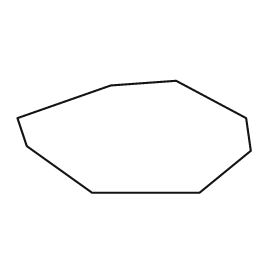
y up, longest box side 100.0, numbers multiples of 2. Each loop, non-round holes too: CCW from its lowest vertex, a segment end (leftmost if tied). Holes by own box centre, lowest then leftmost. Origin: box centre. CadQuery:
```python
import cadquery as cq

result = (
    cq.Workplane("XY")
    .moveTo(-18.0, -24.0)
    .lineTo(28.0, -24.0)
    .lineTo(50.0, -6.0)
    .lineTo(48.0, 8.0)
    .lineTo(18.0, 24.0)
    .lineTo(-10.0, 22.0)
    .lineTo(-50.0, 8.0)
    .lineTo(-46.0, -4.0)
    .close()
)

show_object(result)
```